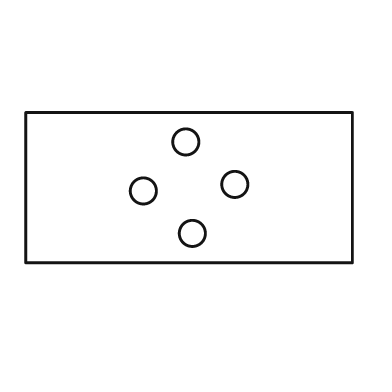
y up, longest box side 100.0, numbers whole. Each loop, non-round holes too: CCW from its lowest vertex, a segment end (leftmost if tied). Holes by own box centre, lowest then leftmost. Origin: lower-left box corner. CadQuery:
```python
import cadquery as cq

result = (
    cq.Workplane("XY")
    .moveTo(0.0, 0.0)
    .lineTo(100.0, 0.0)
    .lineTo(100.0, 46.0)
    .lineTo(0.0, 46.0)
    .close()
    .moveTo(51.0, 9.0)
    .circle(4.0)
    .moveTo(36.0, 22.0)
    .circle(4.0)
    .moveTo(64.0, 24.0)
    .circle(4.0)
    .moveTo(49.0, 37.0)
    .circle(4.0)
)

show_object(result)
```